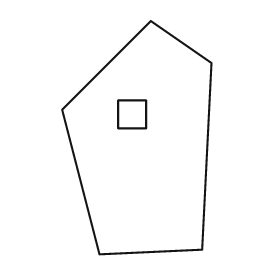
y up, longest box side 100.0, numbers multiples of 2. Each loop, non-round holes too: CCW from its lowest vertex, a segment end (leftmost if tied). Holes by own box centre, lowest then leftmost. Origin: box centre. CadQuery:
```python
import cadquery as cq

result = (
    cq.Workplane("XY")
    .moveTo(-16.0, -50.0)
    .lineTo(28.0, -48.0)
    .lineTo(32.0, 32.0)
    .lineTo(6.0, 50.0)
    .lineTo(-32.0, 12.0)
    .close()
    .moveTo(-8.0, 4.0)
    .lineTo(4.0, 4.0)
    .lineTo(4.0, 16.0)
    .lineTo(-8.0, 16.0)
    .close()
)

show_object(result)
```